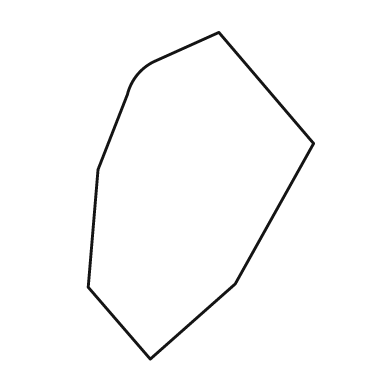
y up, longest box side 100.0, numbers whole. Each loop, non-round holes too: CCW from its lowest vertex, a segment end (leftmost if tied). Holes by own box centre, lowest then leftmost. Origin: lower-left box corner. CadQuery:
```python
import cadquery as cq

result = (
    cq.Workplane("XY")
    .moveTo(19.0, 0.0)
    .lineTo(45.0, 23.0)
    .lineTo(69.0, 66.0)
    .lineTo(40.0, 100.0)
    .lineTo(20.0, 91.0)
    .threePointArc((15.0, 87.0), (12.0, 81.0))
    .lineTo(3.0, 58.0)
    .lineTo(0.0, 22.0)
    .close()
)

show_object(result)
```